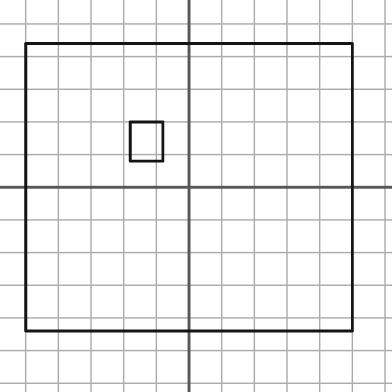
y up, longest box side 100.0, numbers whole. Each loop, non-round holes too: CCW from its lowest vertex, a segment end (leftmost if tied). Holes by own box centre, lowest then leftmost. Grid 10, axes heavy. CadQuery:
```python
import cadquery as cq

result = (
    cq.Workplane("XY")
    .moveTo(-50.0, -44.0)
    .lineTo(50.0, -44.0)
    .lineTo(50.0, 44.0)
    .lineTo(-50.0, 44.0)
    .close()
    .moveTo(-18.0, 8.0)
    .lineTo(-8.0, 8.0)
    .lineTo(-8.0, 20.0)
    .lineTo(-18.0, 20.0)
    .close()
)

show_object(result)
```